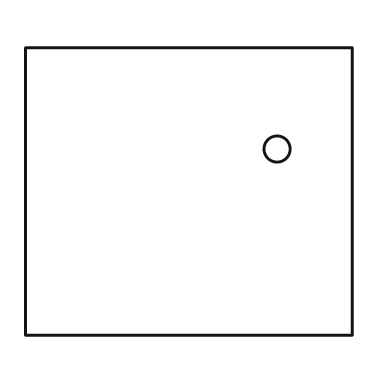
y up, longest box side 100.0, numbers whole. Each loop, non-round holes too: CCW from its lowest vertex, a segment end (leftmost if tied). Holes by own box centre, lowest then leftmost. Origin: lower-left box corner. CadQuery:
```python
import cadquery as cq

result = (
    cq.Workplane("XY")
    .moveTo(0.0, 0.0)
    .lineTo(100.0, 0.0)
    .lineTo(100.0, 88.0)
    .lineTo(0.0, 88.0)
    .close()
    .moveTo(77.0, 57.0)
    .circle(4.0)
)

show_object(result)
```